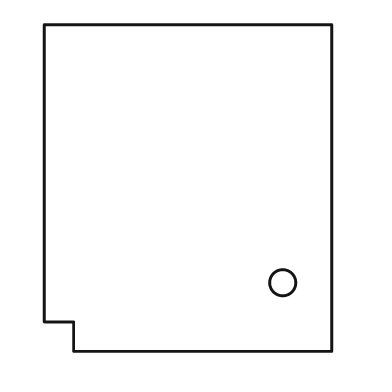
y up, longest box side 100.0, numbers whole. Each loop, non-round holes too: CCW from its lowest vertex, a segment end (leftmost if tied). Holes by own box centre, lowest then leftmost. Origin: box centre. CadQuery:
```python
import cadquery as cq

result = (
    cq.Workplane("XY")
    .moveTo(-35.0, -50.0)
    .lineTo(44.0, -50.0)
    .lineTo(44.0, 50.0)
    .lineTo(-44.0, 50.0)
    .lineTo(-44.0, -41.0)
    .lineTo(-35.0, -41.0)
    .close()
    .moveTo(29.0, -29.0)
    .circle(4.0)
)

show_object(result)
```